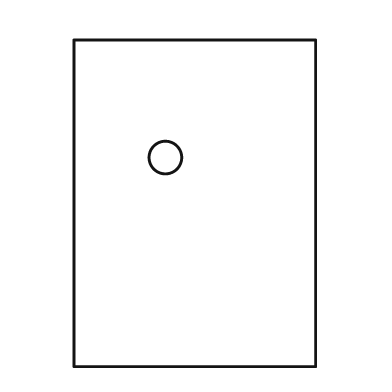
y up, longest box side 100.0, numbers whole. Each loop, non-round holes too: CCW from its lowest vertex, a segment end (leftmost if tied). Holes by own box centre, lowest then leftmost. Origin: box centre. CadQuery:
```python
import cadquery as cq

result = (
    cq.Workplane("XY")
    .moveTo(-37.0, -50.0)
    .lineTo(37.0, -50.0)
    .lineTo(37.0, 50.0)
    .lineTo(-37.0, 50.0)
    .close()
    .moveTo(-9.0, 14.0)
    .circle(5.0)
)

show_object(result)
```